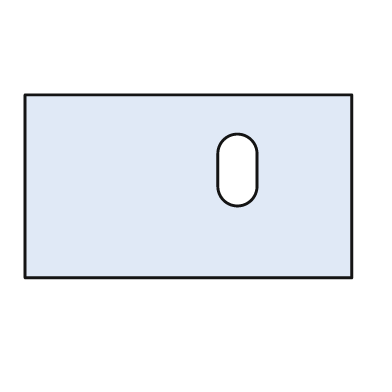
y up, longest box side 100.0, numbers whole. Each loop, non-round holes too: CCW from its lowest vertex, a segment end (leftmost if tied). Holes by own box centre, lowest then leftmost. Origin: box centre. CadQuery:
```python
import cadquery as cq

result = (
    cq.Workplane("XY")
    .moveTo(-50.0, -28.0)
    .lineTo(50.0, -28.0)
    .lineTo(50.0, 28.0)
    .lineTo(-50.0, 28.0)
    .close()
    .moveTo(9.0, 0.0)
    .threePointArc((15.0, -6.0), (21.0, 0.0))
    .lineTo(21.0, 10.0)
    .threePointArc((15.0, 16.0), (9.0, 10.0))
    .close()
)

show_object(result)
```